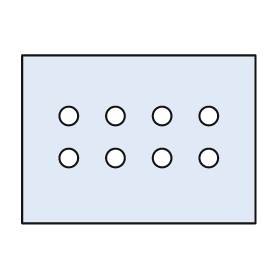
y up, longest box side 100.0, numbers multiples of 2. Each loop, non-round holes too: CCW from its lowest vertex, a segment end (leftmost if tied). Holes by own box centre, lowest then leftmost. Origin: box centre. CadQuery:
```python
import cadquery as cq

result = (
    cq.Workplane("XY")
    .moveTo(-50.0, -36.0)
    .lineTo(50.0, -36.0)
    .lineTo(50.0, 36.0)
    .lineTo(-50.0, 36.0)
    .close()
    .moveTo(-30.0, -8.0)
    .circle(4.0)
    .moveTo(-10.0, -8.0)
    .circle(4.0)
    .moveTo(10.0, -8.0)
    .circle(4.0)
    .moveTo(30.0, -8.0)
    .circle(4.0)
    .moveTo(-30.0, 10.0)
    .circle(4.0)
    .moveTo(-10.0, 10.0)
    .circle(4.0)
    .moveTo(10.0, 10.0)
    .circle(4.0)
    .moveTo(30.0, 10.0)
    .circle(4.0)
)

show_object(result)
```